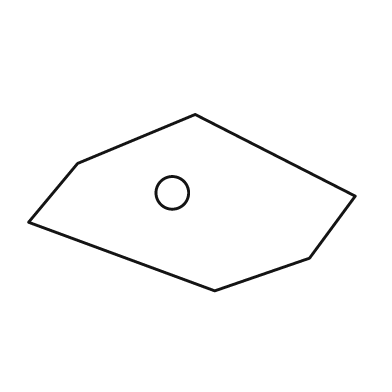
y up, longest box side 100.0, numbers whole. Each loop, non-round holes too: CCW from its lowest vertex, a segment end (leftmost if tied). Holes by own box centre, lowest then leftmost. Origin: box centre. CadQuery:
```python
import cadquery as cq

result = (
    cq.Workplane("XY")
    .moveTo(7.0, -27.0)
    .lineTo(36.0, -17.0)
    .lineTo(50.0, 2.0)
    .lineTo(1.0, 27.0)
    .lineTo(-35.0, 12.0)
    .lineTo(-50.0, -6.0)
    .close()
    .moveTo(-6.0, 3.0)
    .circle(5.0)
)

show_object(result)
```